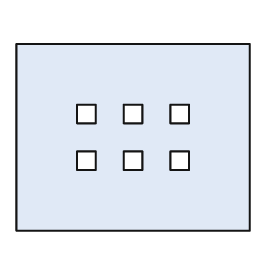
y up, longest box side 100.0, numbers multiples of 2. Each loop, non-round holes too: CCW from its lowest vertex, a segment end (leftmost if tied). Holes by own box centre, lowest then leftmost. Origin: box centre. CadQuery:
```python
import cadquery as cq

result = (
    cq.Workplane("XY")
    .moveTo(-50.0, -40.0)
    .lineTo(50.0, -40.0)
    .lineTo(50.0, 40.0)
    .lineTo(-50.0, 40.0)
    .close()
    .moveTo(-24.0, -14.0)
    .lineTo(-16.0, -14.0)
    .lineTo(-16.0, -6.0)
    .lineTo(-24.0, -6.0)
    .close()
    .moveTo(-4.0, -14.0)
    .lineTo(4.0, -14.0)
    .lineTo(4.0, -6.0)
    .lineTo(-4.0, -6.0)
    .close()
    .moveTo(16.0, -14.0)
    .lineTo(24.0, -14.0)
    .lineTo(24.0, -6.0)
    .lineTo(16.0, -6.0)
    .close()
    .moveTo(-24.0, 6.0)
    .lineTo(-16.0, 6.0)
    .lineTo(-16.0, 14.0)
    .lineTo(-24.0, 14.0)
    .close()
    .moveTo(-4.0, 6.0)
    .lineTo(4.0, 6.0)
    .lineTo(4.0, 14.0)
    .lineTo(-4.0, 14.0)
    .close()
    .moveTo(16.0, 6.0)
    .lineTo(24.0, 6.0)
    .lineTo(24.0, 14.0)
    .lineTo(16.0, 14.0)
    .close()
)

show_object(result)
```